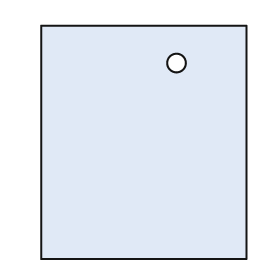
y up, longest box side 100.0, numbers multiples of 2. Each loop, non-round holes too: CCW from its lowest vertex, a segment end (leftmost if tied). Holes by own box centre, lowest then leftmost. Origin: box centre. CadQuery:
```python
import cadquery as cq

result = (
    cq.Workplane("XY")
    .moveTo(-44.0, -50.0)
    .lineTo(44.0, -50.0)
    .lineTo(44.0, 50.0)
    .lineTo(-44.0, 50.0)
    .close()
    .moveTo(14.0, 34.0)
    .circle(4.0)
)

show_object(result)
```